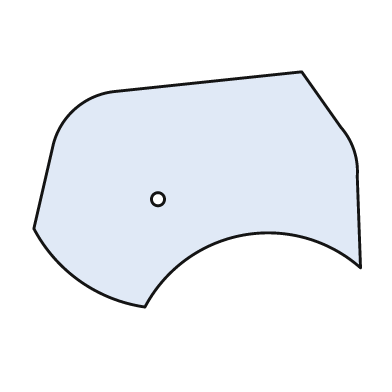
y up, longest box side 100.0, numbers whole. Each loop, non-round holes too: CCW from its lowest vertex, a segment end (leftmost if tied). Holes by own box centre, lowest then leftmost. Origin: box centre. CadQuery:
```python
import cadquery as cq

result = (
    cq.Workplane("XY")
    .moveTo(-16.0, -36.0)
    .threePointArc((14.0, -14.0), (50.0, -24.0))
    .lineTo(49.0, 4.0)
    .threePointArc((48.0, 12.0), (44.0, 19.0))
    .lineTo(32.0, 36.0)
    .lineTo(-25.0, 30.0)
    .threePointArc((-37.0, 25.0), (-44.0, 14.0))
    .lineTo(-50.0, -12.0)
    .threePointArc((-36.0, -28.0), (-16.0, -36.0))
    .close()
    .moveTo(-12.0, -3.0)
    .circle(2.0)
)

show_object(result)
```